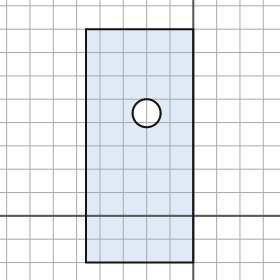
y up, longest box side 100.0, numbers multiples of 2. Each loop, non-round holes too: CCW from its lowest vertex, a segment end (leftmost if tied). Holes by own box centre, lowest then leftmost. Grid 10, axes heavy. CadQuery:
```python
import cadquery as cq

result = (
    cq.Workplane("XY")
    .moveTo(-46.0, -20.0)
    .lineTo(0.0, -20.0)
    .lineTo(0.0, 80.0)
    .lineTo(-46.0, 80.0)
    .close()
    .moveTo(-20.0, 44.0)
    .circle(6.0)
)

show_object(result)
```